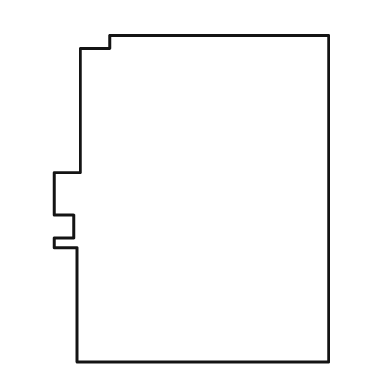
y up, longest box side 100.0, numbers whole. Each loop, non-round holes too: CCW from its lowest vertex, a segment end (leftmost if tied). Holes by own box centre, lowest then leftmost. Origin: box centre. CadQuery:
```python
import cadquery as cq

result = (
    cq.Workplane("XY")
    .moveTo(-35.0, -50.0)
    .lineTo(42.0, -50.0)
    .lineTo(42.0, 50.0)
    .lineTo(-25.0, 50.0)
    .lineTo(-25.0, 46.0)
    .lineTo(-34.0, 46.0)
    .lineTo(-34.0, 8.0)
    .lineTo(-42.0, 8.0)
    .lineTo(-42.0, -5.0)
    .lineTo(-36.0, -5.0)
    .lineTo(-36.0, -12.0)
    .lineTo(-42.0, -12.0)
    .lineTo(-42.0, -15.0)
    .lineTo(-35.0, -15.0)
    .close()
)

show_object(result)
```